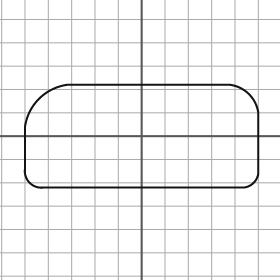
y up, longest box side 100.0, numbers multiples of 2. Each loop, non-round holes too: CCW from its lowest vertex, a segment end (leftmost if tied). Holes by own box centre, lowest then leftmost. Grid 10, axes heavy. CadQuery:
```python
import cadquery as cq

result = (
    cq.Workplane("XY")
    .moveTo(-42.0, -22.0)
    .lineTo(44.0, -22.0)
    .threePointArc((48.0, -20.0), (50.0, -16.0))
    .lineTo(50.0, 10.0)
    .threePointArc((46.0, 18.0), (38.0, 22.0))
    .lineTo(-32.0, 22.0)
    .threePointArc((-44.0, 16.0), (-50.0, 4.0))
    .lineTo(-50.0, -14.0)
    .threePointArc((-48.0, -20.0), (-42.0, -22.0))
    .close()
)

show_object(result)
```